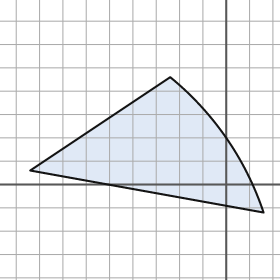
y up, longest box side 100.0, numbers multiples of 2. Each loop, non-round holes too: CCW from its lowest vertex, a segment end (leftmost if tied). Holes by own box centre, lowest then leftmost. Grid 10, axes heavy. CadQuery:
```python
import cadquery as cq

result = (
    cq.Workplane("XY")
    .moveTo(16.0, -12.0)
    .threePointArc((0.0, 20.0), (-24.0, 46.0))
    .lineTo(-84.0, 6.0)
    .close()
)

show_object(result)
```